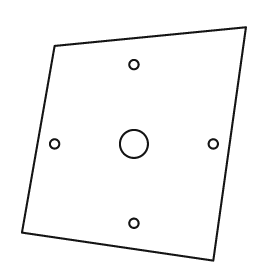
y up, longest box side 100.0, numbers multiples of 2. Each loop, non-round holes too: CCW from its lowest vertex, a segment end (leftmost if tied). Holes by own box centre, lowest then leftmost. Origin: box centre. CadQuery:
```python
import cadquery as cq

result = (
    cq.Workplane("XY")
    .moveTo(34.0, -50.0)
    .lineTo(48.0, 50.0)
    .lineTo(-34.0, 42.0)
    .lineTo(-48.0, -38.0)
    .close()
    .moveTo(0.0, -34.0)
    .circle(2.0)
    .moveTo(-34.0, 0.0)
    .circle(2.0)
    .moveTo(0.0, 0.0)
    .circle(6.0)
    .moveTo(34.0, 0.0)
    .circle(2.0)
    .moveTo(0.0, 34.0)
    .circle(2.0)
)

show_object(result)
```